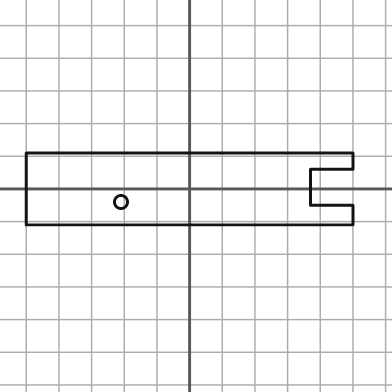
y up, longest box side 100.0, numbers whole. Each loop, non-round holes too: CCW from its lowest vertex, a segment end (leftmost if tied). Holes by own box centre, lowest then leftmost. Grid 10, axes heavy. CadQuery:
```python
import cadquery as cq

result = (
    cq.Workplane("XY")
    .moveTo(-50.0, -11.0)
    .lineTo(50.0, -11.0)
    .lineTo(50.0, -5.0)
    .lineTo(37.0, -5.0)
    .lineTo(37.0, 6.0)
    .lineTo(50.0, 6.0)
    .lineTo(50.0, 11.0)
    .lineTo(-50.0, 11.0)
    .close()
    .moveTo(-21.0, -4.0)
    .circle(2.0)
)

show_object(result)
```